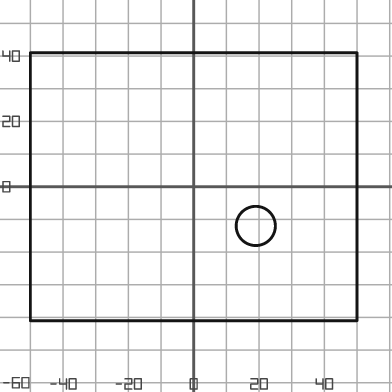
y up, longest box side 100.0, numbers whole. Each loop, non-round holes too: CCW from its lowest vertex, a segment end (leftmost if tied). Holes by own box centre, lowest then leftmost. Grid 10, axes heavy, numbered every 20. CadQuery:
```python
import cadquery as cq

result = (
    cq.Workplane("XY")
    .moveTo(-50.0, -41.0)
    .lineTo(50.0, -41.0)
    .lineTo(50.0, 41.0)
    .lineTo(-50.0, 41.0)
    .close()
    .moveTo(19.0, -12.0)
    .circle(6.0)
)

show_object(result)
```